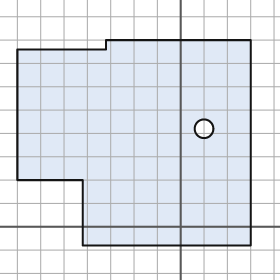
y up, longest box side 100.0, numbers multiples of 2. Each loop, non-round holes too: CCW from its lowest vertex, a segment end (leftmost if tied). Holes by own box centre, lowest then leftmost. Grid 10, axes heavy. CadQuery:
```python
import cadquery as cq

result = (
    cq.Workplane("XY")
    .moveTo(-42.0, -8.0)
    .lineTo(30.0, -8.0)
    .lineTo(30.0, 80.0)
    .lineTo(-32.0, 80.0)
    .lineTo(-32.0, 76.0)
    .lineTo(-70.0, 76.0)
    .lineTo(-70.0, 20.0)
    .lineTo(-42.0, 20.0)
    .close()
    .moveTo(10.0, 42.0)
    .circle(4.0)
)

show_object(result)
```